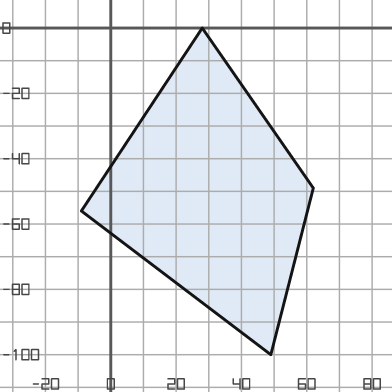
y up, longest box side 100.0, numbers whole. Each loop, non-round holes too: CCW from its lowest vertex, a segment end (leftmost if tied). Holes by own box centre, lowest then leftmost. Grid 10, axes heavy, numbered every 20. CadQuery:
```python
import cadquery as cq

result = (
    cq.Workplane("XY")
    .moveTo(49.0, -100.0)
    .lineTo(62.0, -49.0)
    .lineTo(28.0, 0.0)
    .lineTo(-9.0, -56.0)
    .close()
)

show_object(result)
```